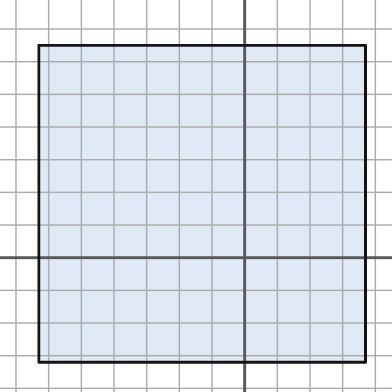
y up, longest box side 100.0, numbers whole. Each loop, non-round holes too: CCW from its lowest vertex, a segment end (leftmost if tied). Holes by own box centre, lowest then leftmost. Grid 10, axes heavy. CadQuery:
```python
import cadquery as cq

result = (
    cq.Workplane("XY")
    .moveTo(-63.0, -32.0)
    .lineTo(37.0, -32.0)
    .lineTo(37.0, 65.0)
    .lineTo(-63.0, 65.0)
    .close()
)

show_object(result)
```